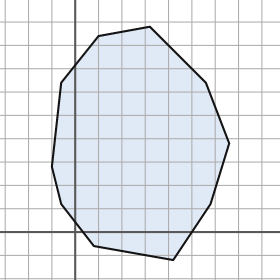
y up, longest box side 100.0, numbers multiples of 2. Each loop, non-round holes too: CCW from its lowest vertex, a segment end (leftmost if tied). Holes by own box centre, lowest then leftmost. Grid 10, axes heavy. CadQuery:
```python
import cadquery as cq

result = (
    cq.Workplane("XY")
    .moveTo(42.0, -12.0)
    .lineTo(58.0, 12.0)
    .lineTo(66.0, 38.0)
    .lineTo(56.0, 64.0)
    .lineTo(32.0, 88.0)
    .lineTo(10.0, 84.0)
    .lineTo(-6.0, 64.0)
    .lineTo(-10.0, 28.0)
    .lineTo(-6.0, 12.0)
    .lineTo(8.0, -6.0)
    .close()
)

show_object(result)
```